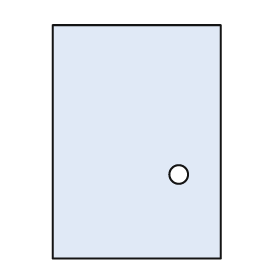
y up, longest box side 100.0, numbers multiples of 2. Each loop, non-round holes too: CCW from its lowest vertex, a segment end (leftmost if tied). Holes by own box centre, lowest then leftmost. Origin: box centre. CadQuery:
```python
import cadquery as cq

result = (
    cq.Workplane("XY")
    .moveTo(-36.0, -50.0)
    .lineTo(36.0, -50.0)
    .lineTo(36.0, 50.0)
    .lineTo(-36.0, 50.0)
    .close()
    .moveTo(18.0, -14.0)
    .circle(4.0)
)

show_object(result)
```